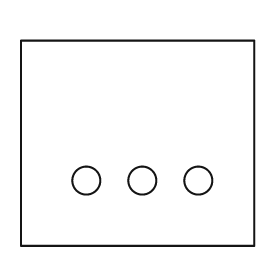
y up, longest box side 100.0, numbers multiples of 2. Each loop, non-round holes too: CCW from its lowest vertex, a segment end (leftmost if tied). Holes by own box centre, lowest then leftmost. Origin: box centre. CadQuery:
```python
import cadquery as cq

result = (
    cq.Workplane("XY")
    .moveTo(-50.0, -44.0)
    .lineTo(50.0, -44.0)
    .lineTo(50.0, 44.0)
    .lineTo(-50.0, 44.0)
    .close()
    .moveTo(-22.0, -16.0)
    .circle(6.0)
    .moveTo(2.0, -16.0)
    .circle(6.0)
    .moveTo(26.0, -16.0)
    .circle(6.0)
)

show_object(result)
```